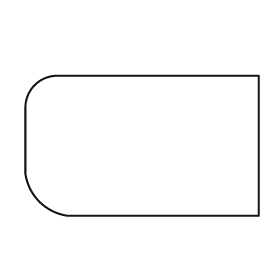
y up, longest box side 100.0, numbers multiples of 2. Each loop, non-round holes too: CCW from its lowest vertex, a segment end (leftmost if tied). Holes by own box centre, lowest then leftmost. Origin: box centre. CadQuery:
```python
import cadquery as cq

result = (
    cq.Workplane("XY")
    .moveTo(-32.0, -30.0)
    .lineTo(50.0, -30.0)
    .lineTo(50.0, 30.0)
    .lineTo(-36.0, 30.0)
    .threePointArc((-46.0, 26.0), (-50.0, 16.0))
    .lineTo(-50.0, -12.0)
    .threePointArc((-44.0, -24.0), (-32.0, -30.0))
    .close()
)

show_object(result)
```